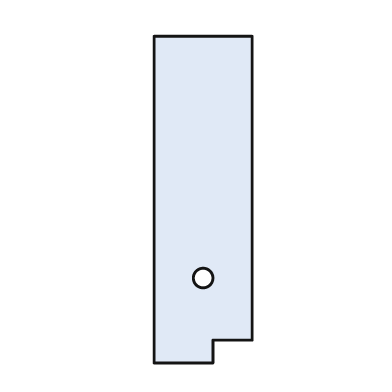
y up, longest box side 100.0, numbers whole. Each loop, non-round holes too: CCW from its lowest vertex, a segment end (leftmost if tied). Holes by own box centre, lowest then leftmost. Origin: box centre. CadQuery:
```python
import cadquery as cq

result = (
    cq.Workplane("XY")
    .moveTo(-15.0, -50.0)
    .lineTo(3.0, -50.0)
    .lineTo(3.0, -43.0)
    .lineTo(15.0, -43.0)
    .lineTo(15.0, 50.0)
    .lineTo(-15.0, 50.0)
    .close()
    .moveTo(0.0, -24.0)
    .circle(3.0)
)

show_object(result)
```